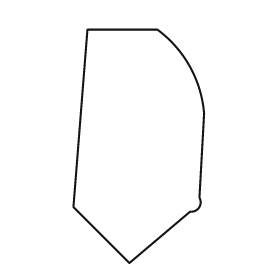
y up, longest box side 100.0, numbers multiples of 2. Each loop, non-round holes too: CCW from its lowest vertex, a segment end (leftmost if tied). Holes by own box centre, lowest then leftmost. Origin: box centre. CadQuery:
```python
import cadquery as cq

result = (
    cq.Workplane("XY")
    .moveTo(-4.0, -50.0)
    .lineTo(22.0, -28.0)
    .threePointArc((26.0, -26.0), (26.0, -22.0))
    .lineTo(28.0, 14.0)
    .threePointArc((22.0, 34.0), (8.0, 50.0))
    .lineTo(-22.0, 50.0)
    .lineTo(-28.0, -26.0)
    .close()
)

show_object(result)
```